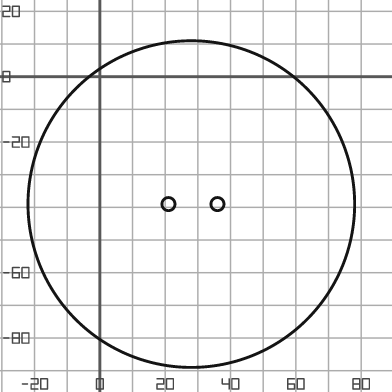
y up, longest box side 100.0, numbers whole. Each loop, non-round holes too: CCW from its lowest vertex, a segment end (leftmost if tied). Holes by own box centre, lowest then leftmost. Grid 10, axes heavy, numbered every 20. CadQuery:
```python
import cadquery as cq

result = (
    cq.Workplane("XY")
    .moveTo(28.0, -39.0)
    .circle(50.0)
    .moveTo(21.0, -39.0)
    .circle(2.0)
    .moveTo(36.0, -39.0)
    .circle(2.0)
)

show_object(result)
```